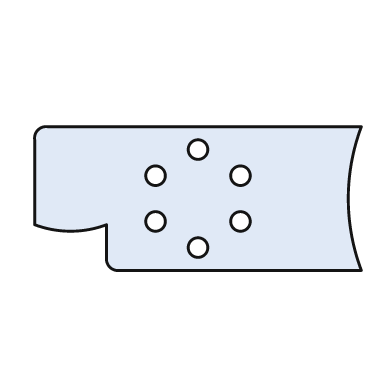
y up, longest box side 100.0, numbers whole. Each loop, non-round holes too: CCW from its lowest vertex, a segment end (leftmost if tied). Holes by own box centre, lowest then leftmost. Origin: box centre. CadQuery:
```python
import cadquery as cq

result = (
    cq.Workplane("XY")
    .moveTo(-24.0, -22.0)
    .lineTo(50.0, -22.0)
    .threePointArc((46.0, 0.0), (50.0, 22.0))
    .lineTo(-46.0, 22.0)
    .threePointArc((-49.0, 21.0), (-50.0, 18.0))
    .lineTo(-50.0, -8.0)
    .threePointArc((-39.0, -10.0), (-28.0, -8.0))
    .lineTo(-28.0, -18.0)
    .threePointArc((-27.0, -21.0), (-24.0, -22.0))
    .close()
    .moveTo(0.0, -15.0)
    .circle(3.0)
    .moveTo(-13.0, -7.0)
    .circle(3.0)
    .moveTo(13.0, -7.0)
    .circle(3.0)
    .moveTo(-13.0, 7.0)
    .circle(3.0)
    .moveTo(13.0, 7.0)
    .circle(3.0)
    .moveTo(0.0, 15.0)
    .circle(3.0)
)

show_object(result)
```